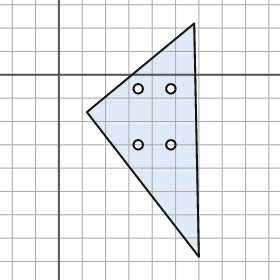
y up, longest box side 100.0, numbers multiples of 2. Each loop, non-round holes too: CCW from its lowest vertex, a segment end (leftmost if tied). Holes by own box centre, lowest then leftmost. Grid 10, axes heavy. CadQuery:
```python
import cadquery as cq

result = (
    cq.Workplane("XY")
    .moveTo(60.0, -78.0)
    .lineTo(58.0, 22.0)
    .lineTo(12.0, -16.0)
    .close()
    .moveTo(34.0, -30.0)
    .circle(2.0)
    .moveTo(48.0, -30.0)
    .circle(2.0)
    .moveTo(34.0, -6.0)
    .circle(2.0)
    .moveTo(48.0, -6.0)
    .circle(2.0)
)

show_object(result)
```